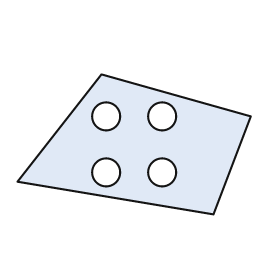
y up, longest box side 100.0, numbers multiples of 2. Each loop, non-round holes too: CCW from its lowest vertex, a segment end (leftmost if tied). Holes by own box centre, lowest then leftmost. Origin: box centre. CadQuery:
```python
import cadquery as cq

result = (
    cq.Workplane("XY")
    .moveTo(34.0, -30.0)
    .lineTo(50.0, 12.0)
    .lineTo(-14.0, 30.0)
    .lineTo(-50.0, -16.0)
    .close()
    .moveTo(-12.0, -12.0)
    .circle(6.0)
    .moveTo(12.0, -12.0)
    .circle(6.0)
    .moveTo(-12.0, 12.0)
    .circle(6.0)
    .moveTo(12.0, 12.0)
    .circle(6.0)
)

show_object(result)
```